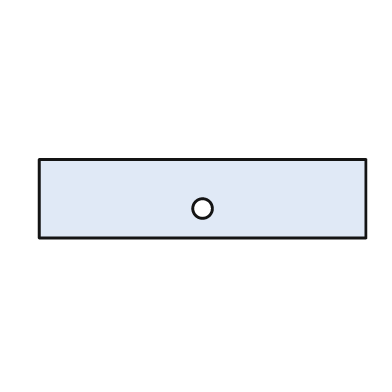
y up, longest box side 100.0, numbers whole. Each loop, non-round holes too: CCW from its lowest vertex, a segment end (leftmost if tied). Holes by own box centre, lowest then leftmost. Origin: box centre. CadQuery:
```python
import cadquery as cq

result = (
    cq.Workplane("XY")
    .moveTo(-50.0, -12.0)
    .lineTo(50.0, -12.0)
    .lineTo(50.0, 12.0)
    .lineTo(-50.0, 12.0)
    .close()
    .moveTo(0.0, -3.0)
    .circle(3.0)
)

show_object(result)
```